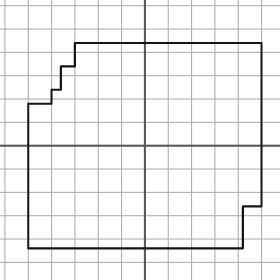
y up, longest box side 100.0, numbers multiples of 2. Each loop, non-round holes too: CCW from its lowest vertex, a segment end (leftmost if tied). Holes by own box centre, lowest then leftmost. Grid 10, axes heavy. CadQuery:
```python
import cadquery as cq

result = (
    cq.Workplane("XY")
    .moveTo(-50.0, -44.0)
    .lineTo(42.0, -44.0)
    .lineTo(42.0, -26.0)
    .lineTo(50.0, -26.0)
    .lineTo(50.0, 44.0)
    .lineTo(-30.0, 44.0)
    .lineTo(-30.0, 34.0)
    .lineTo(-36.0, 34.0)
    .lineTo(-36.0, 24.0)
    .lineTo(-40.0, 24.0)
    .lineTo(-40.0, 18.0)
    .lineTo(-50.0, 18.0)
    .close()
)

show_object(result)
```